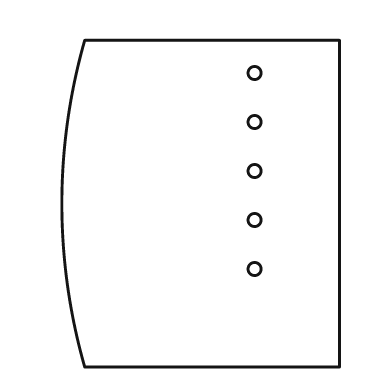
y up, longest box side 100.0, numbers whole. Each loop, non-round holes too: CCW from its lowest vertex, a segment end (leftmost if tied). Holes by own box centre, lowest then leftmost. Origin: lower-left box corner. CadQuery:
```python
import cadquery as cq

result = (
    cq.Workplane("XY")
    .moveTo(7.0, 0.0)
    .lineTo(85.0, 0.0)
    .lineTo(85.0, 100.0)
    .lineTo(7.0, 100.0)
    .threePointArc((0.0, 50.0), (7.0, 0.0))
    .close()
    .moveTo(59.0, 30.0)
    .circle(2.0)
    .moveTo(59.0, 45.0)
    .circle(2.0)
    .moveTo(59.0, 60.0)
    .circle(2.0)
    .moveTo(59.0, 75.0)
    .circle(2.0)
    .moveTo(59.0, 90.0)
    .circle(2.0)
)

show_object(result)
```